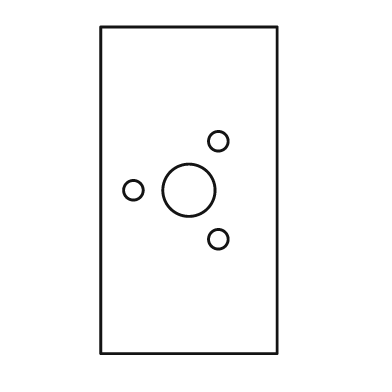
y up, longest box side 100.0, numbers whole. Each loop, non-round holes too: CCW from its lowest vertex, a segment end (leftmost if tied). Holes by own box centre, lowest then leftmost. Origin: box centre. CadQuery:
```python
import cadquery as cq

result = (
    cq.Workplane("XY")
    .moveTo(-27.0, -50.0)
    .lineTo(27.0, -50.0)
    .lineTo(27.0, 50.0)
    .lineTo(-27.0, 50.0)
    .close()
    .moveTo(9.0, -15.0)
    .circle(3.0)
    .moveTo(-17.0, 0.0)
    .circle(3.0)
    .moveTo(0.0, 0.0)
    .circle(8.0)
    .moveTo(9.0, 15.0)
    .circle(3.0)
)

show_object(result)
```